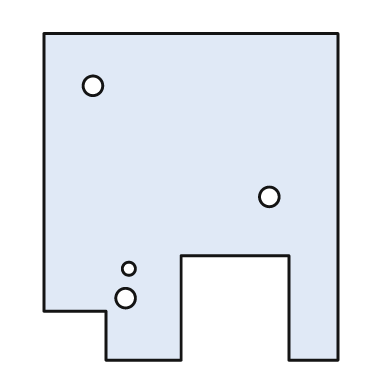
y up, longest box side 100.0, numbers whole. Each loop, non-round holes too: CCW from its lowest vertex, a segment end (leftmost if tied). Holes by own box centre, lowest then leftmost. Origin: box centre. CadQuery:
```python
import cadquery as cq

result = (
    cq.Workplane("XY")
    .moveTo(-26.0, -50.0)
    .lineTo(-3.0, -50.0)
    .lineTo(-3.0, -18.0)
    .lineTo(30.0, -18.0)
    .lineTo(30.0, -50.0)
    .lineTo(45.0, -50.0)
    .lineTo(45.0, 50.0)
    .lineTo(-45.0, 50.0)
    .lineTo(-45.0, -35.0)
    .lineTo(-26.0, -35.0)
    .close()
    .moveTo(-20.0, -31.0)
    .circle(3.0)
    .moveTo(-19.0, -22.0)
    .circle(2.0)
    .moveTo(24.0, 0.0)
    .circle(3.0)
    .moveTo(-30.0, 34.0)
    .circle(3.0)
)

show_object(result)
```